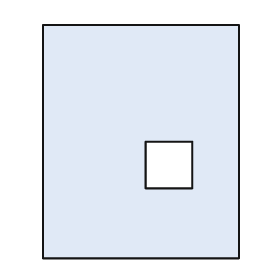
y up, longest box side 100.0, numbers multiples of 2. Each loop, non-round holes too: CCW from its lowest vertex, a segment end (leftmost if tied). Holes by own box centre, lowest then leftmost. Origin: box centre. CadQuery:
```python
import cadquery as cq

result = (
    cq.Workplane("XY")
    .moveTo(-42.0, -50.0)
    .lineTo(42.0, -50.0)
    .lineTo(42.0, 50.0)
    .lineTo(-42.0, 50.0)
    .close()
    .moveTo(2.0, -20.0)
    .lineTo(22.0, -20.0)
    .lineTo(22.0, 0.0)
    .lineTo(2.0, 0.0)
    .close()
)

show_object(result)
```